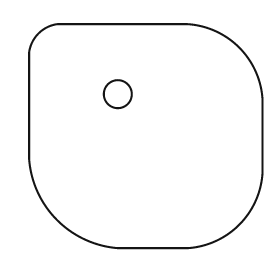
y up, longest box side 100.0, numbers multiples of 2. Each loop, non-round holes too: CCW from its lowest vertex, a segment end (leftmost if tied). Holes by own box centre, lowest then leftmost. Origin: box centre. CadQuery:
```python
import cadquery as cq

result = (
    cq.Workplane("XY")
    .moveTo(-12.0, -48.0)
    .lineTo(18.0, -48.0)
    .threePointArc((40.0, -38.0), (50.0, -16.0))
    .lineTo(50.0, 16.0)
    .threePointArc((40.0, 38.0), (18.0, 48.0))
    .lineTo(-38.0, 48.0)
    .threePointArc((-46.0, 44.0), (-50.0, 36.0))
    .lineTo(-50.0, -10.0)
    .threePointArc((-38.0, -36.0), (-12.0, -48.0))
    .close()
    .moveTo(-12.0, 18.0)
    .circle(6.0)
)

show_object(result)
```